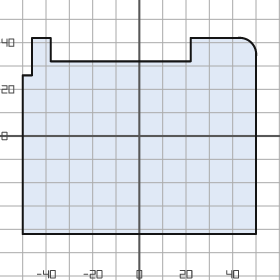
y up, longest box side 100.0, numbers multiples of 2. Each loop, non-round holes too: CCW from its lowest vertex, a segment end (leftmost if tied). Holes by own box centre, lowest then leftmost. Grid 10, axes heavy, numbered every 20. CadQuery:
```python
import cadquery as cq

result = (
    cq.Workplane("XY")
    .moveTo(-50.0, -42.0)
    .lineTo(50.0, -42.0)
    .lineTo(50.0, 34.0)
    .threePointArc((48.0, 40.0), (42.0, 42.0))
    .lineTo(22.0, 42.0)
    .lineTo(22.0, 32.0)
    .lineTo(-38.0, 32.0)
    .lineTo(-38.0, 42.0)
    .lineTo(-46.0, 42.0)
    .lineTo(-46.0, 26.0)
    .lineTo(-50.0, 26.0)
    .close()
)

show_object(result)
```